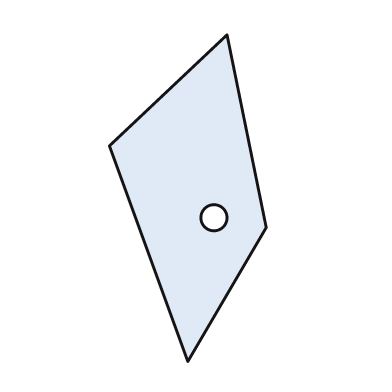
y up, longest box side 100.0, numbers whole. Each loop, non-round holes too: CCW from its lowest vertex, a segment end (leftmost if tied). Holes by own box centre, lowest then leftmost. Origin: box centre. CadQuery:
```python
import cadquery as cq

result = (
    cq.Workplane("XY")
    .moveTo(0.0, -50.0)
    .lineTo(24.0, -9.0)
    .lineTo(12.0, 50.0)
    .lineTo(-24.0, 16.0)
    .close()
    .moveTo(8.0, -6.0)
    .circle(4.0)
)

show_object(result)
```